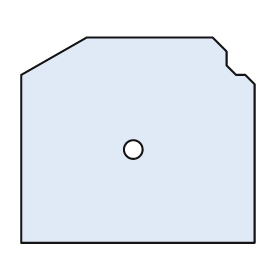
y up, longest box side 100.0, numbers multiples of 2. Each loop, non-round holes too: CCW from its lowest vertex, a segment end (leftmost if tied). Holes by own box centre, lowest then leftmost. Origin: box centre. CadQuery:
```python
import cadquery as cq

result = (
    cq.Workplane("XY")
    .moveTo(-50.0, -44.0)
    .lineTo(50.0, -44.0)
    .lineTo(50.0, 24.0)
    .lineTo(46.0, 28.0)
    .lineTo(42.0, 28.0)
    .lineTo(38.0, 32.0)
    .lineTo(38.0, 38.0)
    .lineTo(32.0, 44.0)
    .lineTo(-22.0, 44.0)
    .lineTo(-50.0, 28.0)
    .close()
    .moveTo(-2.0, -4.0)
    .circle(4.0)
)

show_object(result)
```